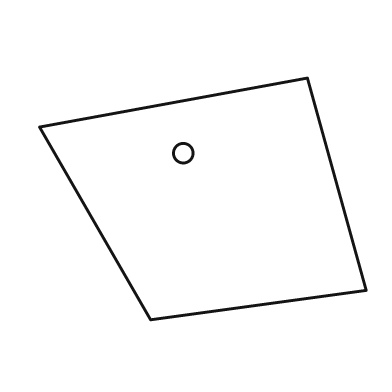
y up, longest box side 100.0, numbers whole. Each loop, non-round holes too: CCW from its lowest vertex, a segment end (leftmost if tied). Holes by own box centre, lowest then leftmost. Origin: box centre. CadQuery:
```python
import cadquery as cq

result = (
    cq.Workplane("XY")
    .moveTo(-16.0, -37.0)
    .lineTo(50.0, -28.0)
    .lineTo(32.0, 37.0)
    .lineTo(-50.0, 22.0)
    .close()
    .moveTo(-6.0, 14.0)
    .circle(3.0)
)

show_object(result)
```